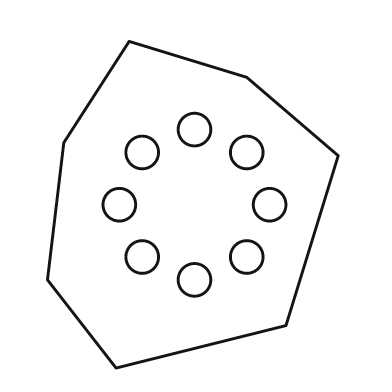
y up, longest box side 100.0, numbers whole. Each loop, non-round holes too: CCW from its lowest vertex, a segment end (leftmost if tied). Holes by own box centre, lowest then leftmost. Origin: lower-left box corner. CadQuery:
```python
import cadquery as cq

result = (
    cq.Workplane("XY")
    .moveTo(21.0, 0.0)
    .lineTo(73.0, 13.0)
    .lineTo(89.0, 65.0)
    .lineTo(61.0, 89.0)
    .lineTo(25.0, 100.0)
    .lineTo(5.0, 69.0)
    .lineTo(0.0, 27.0)
    .close()
    .moveTo(45.0, 27.0)
    .circle(5.0)
    .moveTo(29.0, 34.0)
    .circle(5.0)
    .moveTo(61.0, 34.0)
    .circle(5.0)
    .moveTo(22.0, 50.0)
    .circle(5.0)
    .moveTo(68.0, 50.0)
    .circle(5.0)
    .moveTo(29.0, 66.0)
    .circle(5.0)
    .moveTo(61.0, 66.0)
    .circle(5.0)
    .moveTo(45.0, 73.0)
    .circle(5.0)
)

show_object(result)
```